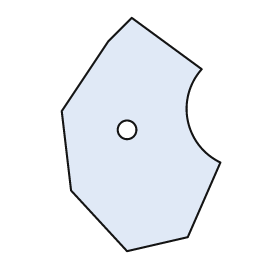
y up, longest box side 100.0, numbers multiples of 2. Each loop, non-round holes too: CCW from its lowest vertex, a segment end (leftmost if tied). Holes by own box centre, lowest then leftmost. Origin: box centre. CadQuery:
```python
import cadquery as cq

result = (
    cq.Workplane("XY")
    .moveTo(-6.0, -50.0)
    .lineTo(20.0, -44.0)
    .lineTo(34.0, -12.0)
    .threePointArc((20.0, 6.0), (26.0, 28.0))
    .lineTo(-4.0, 50.0)
    .lineTo(-14.0, 40.0)
    .lineTo(-34.0, 10.0)
    .lineTo(-30.0, -24.0)
    .close()
    .moveTo(-6.0, 2.0)
    .circle(4.0)
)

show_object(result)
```